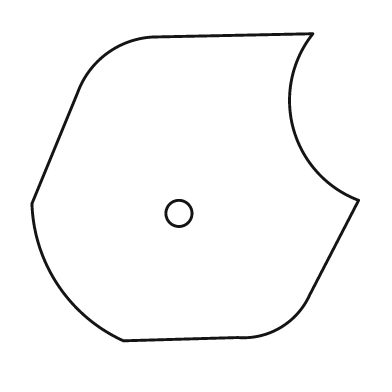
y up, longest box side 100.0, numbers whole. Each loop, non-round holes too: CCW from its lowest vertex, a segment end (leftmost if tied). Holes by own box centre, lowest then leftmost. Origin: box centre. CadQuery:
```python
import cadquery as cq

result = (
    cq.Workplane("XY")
    .moveTo(-22.0, -47.0)
    .lineTo(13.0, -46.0)
    .threePointArc((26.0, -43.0), (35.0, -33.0))
    .lineTo(50.0, -4.0)
    .threePointArc((30.0, 18.0), (36.0, 47.0))
    .lineTo(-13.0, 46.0)
    .threePointArc((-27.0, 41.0), (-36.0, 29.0))
    .lineTo(-50.0, -5.0)
    .threePointArc((-42.0, -30.0), (-22.0, -47.0))
    .close()
    .moveTo(-5.0, -8.0)
    .circle(4.0)
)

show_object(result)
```